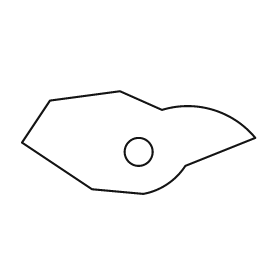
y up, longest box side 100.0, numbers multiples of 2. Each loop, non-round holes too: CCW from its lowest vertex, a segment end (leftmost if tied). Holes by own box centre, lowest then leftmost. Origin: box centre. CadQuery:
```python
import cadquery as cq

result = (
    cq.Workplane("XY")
    .moveTo(2.0, -22.0)
    .threePointArc((12.0, -18.0), (20.0, -10.0))
    .lineTo(50.0, 2.0)
    .threePointArc((32.0, 14.0), (10.0, 14.0))
    .lineTo(-8.0, 22.0)
    .lineTo(-38.0, 18.0)
    .lineTo(-50.0, 0.0)
    .lineTo(-20.0, -20.0)
    .close()
    .moveTo(0.0, -4.0)
    .circle(6.0)
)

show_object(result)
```